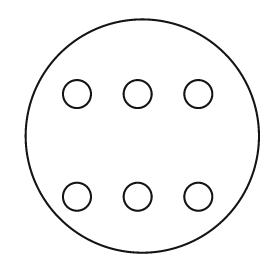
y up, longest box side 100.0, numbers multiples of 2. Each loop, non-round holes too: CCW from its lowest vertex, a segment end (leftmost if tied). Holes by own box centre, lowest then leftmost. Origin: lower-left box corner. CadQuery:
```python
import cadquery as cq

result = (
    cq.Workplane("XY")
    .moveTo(50.0, 50.0)
    .circle(50.0)
    .moveTo(22.0, 24.0)
    .circle(6.0)
    .moveTo(48.0, 24.0)
    .circle(6.0)
    .moveTo(74.0, 24.0)
    .circle(6.0)
    .moveTo(22.0, 68.0)
    .circle(6.0)
    .moveTo(48.0, 68.0)
    .circle(6.0)
    .moveTo(74.0, 68.0)
    .circle(6.0)
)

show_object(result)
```